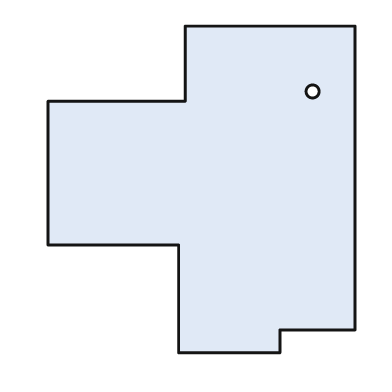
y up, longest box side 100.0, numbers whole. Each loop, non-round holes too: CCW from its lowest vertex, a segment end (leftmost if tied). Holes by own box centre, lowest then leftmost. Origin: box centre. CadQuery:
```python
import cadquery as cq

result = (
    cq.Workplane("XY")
    .moveTo(-7.0, -50.0)
    .lineTo(24.0, -50.0)
    .lineTo(24.0, -43.0)
    .lineTo(47.0, -43.0)
    .lineTo(47.0, 50.0)
    .lineTo(-5.0, 50.0)
    .lineTo(-5.0, 27.0)
    .lineTo(-47.0, 27.0)
    .lineTo(-47.0, -17.0)
    .lineTo(-7.0, -17.0)
    .close()
    .moveTo(34.0, 30.0)
    .circle(2.0)
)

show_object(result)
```